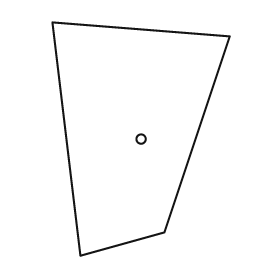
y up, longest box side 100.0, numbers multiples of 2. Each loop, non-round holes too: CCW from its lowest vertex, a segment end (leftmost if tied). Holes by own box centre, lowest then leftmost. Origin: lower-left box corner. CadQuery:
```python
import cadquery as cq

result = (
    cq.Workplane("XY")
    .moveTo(12.0, 0.0)
    .lineTo(48.0, 10.0)
    .lineTo(76.0, 94.0)
    .lineTo(0.0, 100.0)
    .close()
    .moveTo(38.0, 50.0)
    .circle(2.0)
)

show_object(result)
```